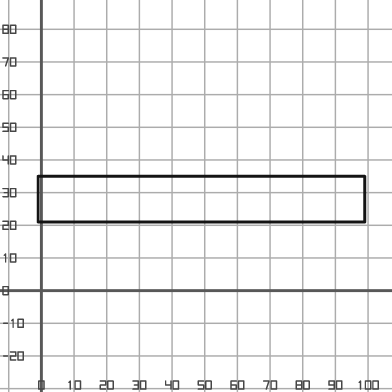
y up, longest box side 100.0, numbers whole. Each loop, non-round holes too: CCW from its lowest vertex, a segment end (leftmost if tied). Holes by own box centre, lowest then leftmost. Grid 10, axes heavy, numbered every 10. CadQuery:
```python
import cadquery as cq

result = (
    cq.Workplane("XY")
    .moveTo(-1.0, 21.0)
    .lineTo(99.0, 21.0)
    .lineTo(99.0, 35.0)
    .lineTo(-1.0, 35.0)
    .close()
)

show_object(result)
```